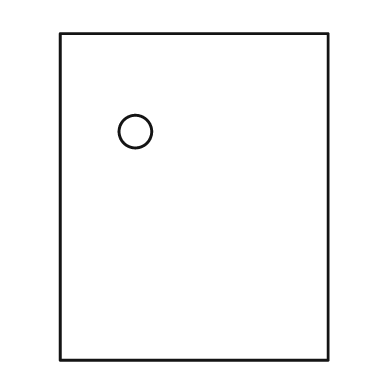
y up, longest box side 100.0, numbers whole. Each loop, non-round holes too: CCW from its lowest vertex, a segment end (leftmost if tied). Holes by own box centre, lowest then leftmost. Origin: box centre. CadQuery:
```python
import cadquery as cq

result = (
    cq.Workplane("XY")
    .moveTo(-41.0, -50.0)
    .lineTo(41.0, -50.0)
    .lineTo(41.0, 50.0)
    .lineTo(-41.0, 50.0)
    .close()
    .moveTo(-18.0, 20.0)
    .circle(5.0)
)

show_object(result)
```